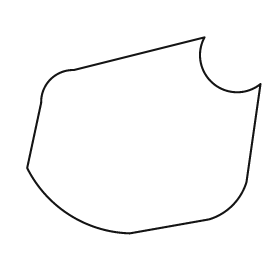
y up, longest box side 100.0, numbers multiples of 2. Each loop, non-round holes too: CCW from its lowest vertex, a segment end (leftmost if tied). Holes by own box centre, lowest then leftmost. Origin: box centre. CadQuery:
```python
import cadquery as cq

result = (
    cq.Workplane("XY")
    .moveTo(-6.0, -42.0)
    .lineTo(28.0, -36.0)
    .threePointArc((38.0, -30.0), (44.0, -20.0))
    .lineTo(50.0, 22.0)
    .threePointArc((30.0, 22.0), (26.0, 42.0))
    .lineTo(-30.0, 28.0)
    .threePointArc((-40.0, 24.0), (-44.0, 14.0))
    .lineTo(-50.0, -14.0)
    .threePointArc((-32.0, -34.0), (-6.0, -42.0))
    .close()
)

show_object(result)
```